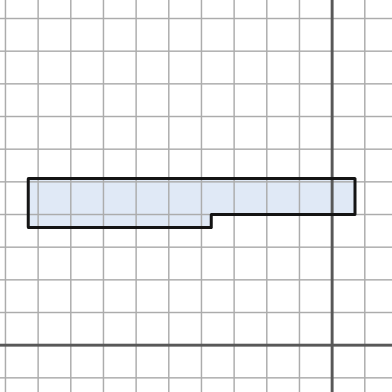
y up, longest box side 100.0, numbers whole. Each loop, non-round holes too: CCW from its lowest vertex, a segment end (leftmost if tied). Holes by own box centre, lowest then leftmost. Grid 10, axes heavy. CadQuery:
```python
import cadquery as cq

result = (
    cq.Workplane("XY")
    .moveTo(-93.0, 36.0)
    .lineTo(-37.0, 36.0)
    .lineTo(-37.0, 40.0)
    .lineTo(7.0, 40.0)
    .lineTo(7.0, 51.0)
    .lineTo(-93.0, 51.0)
    .close()
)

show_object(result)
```